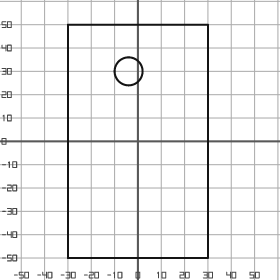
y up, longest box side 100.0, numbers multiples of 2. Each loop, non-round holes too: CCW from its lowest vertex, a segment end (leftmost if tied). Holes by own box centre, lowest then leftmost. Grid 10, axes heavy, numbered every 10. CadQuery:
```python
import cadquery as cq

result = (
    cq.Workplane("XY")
    .moveTo(-30.0, -50.0)
    .lineTo(30.0, -50.0)
    .lineTo(30.0, 50.0)
    .lineTo(-30.0, 50.0)
    .close()
    .moveTo(-4.0, 30.0)
    .circle(6.0)
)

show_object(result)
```